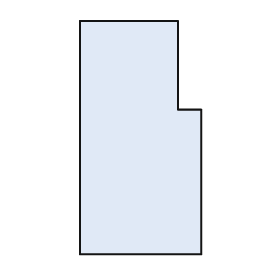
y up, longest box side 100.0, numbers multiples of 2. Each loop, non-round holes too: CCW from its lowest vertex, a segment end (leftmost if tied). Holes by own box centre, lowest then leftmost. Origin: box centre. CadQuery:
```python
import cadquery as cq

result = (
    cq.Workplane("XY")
    .moveTo(-26.0, -50.0)
    .lineTo(26.0, -50.0)
    .lineTo(26.0, 12.0)
    .lineTo(16.0, 12.0)
    .lineTo(16.0, 50.0)
    .lineTo(-26.0, 50.0)
    .close()
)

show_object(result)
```